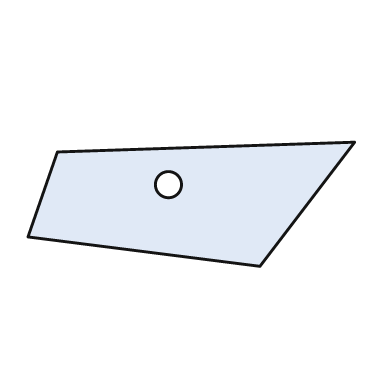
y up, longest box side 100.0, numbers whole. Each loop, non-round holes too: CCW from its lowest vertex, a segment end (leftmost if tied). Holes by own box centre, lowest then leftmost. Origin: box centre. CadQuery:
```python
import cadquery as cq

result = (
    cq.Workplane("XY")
    .moveTo(21.0, -19.0)
    .lineTo(50.0, 19.0)
    .lineTo(-41.0, 16.0)
    .lineTo(-50.0, -10.0)
    .close()
    .moveTo(-7.0, 6.0)
    .circle(4.0)
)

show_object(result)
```